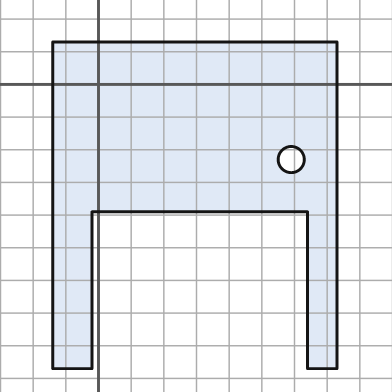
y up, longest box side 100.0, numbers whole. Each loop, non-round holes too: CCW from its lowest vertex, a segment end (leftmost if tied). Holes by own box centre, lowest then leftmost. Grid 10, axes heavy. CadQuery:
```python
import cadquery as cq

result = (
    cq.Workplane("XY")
    .moveTo(-14.0, -87.0)
    .lineTo(-2.0, -87.0)
    .lineTo(-2.0, -39.0)
    .lineTo(64.0, -39.0)
    .lineTo(64.0, -87.0)
    .lineTo(73.0, -87.0)
    .lineTo(73.0, 13.0)
    .lineTo(-14.0, 13.0)
    .close()
    .moveTo(59.0, -23.0)
    .circle(4.0)
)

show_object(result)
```